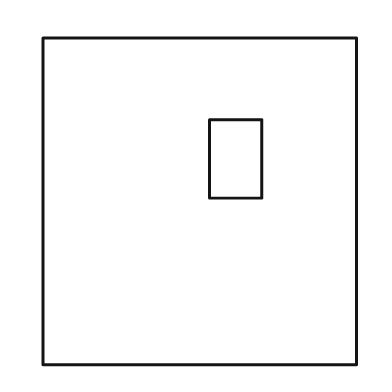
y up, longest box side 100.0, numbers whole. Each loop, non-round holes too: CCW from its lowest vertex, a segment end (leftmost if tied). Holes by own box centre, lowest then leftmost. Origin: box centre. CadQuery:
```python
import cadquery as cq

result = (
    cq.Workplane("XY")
    .moveTo(-48.0, -50.0)
    .lineTo(48.0, -50.0)
    .lineTo(48.0, 50.0)
    .lineTo(-48.0, 50.0)
    .close()
    .moveTo(3.0, 1.0)
    .lineTo(19.0, 1.0)
    .lineTo(19.0, 25.0)
    .lineTo(3.0, 25.0)
    .close()
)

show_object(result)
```